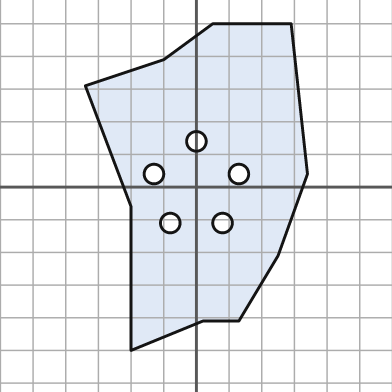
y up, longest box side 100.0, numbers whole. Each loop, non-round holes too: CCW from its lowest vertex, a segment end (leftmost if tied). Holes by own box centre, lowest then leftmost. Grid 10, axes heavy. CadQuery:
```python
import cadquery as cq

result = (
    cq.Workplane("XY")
    .moveTo(-20.0, -50.0)
    .lineTo(2.0, -41.0)
    .lineTo(13.0, -41.0)
    .lineTo(25.0, -21.0)
    .lineTo(34.0, 4.0)
    .lineTo(29.0, 50.0)
    .lineTo(5.0, 50.0)
    .lineTo(-10.0, 39.0)
    .lineTo(-34.0, 31.0)
    .lineTo(-20.0, -6.0)
    .close()
    .moveTo(-8.0, -11.0)
    .circle(3.0)
    .moveTo(8.0, -11.0)
    .circle(3.0)
    .moveTo(-13.0, 4.0)
    .circle(3.0)
    .moveTo(13.0, 4.0)
    .circle(3.0)
    .moveTo(0.0, 14.0)
    .circle(3.0)
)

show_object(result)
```